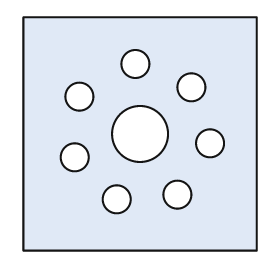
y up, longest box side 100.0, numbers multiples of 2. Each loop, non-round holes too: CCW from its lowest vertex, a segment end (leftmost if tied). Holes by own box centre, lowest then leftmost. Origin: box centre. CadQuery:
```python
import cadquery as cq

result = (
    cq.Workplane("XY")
    .moveTo(-50.0, -50.0)
    .lineTo(50.0, -50.0)
    .lineTo(50.0, 50.0)
    .lineTo(-50.0, 50.0)
    .close()
    .moveTo(-10.0, -28.0)
    .circle(6.0)
    .moveTo(16.0, -26.0)
    .circle(6.0)
    .moveTo(-28.0, -10.0)
    .circle(6.0)
    .moveTo(30.0, -4.0)
    .circle(6.0)
    .moveTo(0.0, 0.0)
    .circle(12.0)
    .moveTo(-26.0, 16.0)
    .circle(6.0)
    .moveTo(22.0, 20.0)
    .circle(6.0)
    .moveTo(-2.0, 30.0)
    .circle(6.0)
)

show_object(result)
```